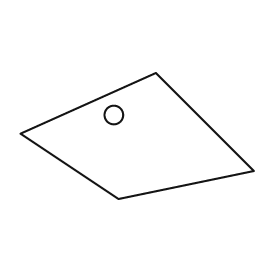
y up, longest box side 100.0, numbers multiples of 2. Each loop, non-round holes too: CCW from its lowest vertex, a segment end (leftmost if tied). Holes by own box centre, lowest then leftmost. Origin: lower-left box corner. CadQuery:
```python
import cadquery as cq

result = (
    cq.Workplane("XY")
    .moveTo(42.0, 0.0)
    .lineTo(100.0, 12.0)
    .lineTo(58.0, 54.0)
    .lineTo(0.0, 28.0)
    .close()
    .moveTo(40.0, 36.0)
    .circle(4.0)
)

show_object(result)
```